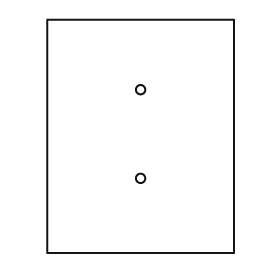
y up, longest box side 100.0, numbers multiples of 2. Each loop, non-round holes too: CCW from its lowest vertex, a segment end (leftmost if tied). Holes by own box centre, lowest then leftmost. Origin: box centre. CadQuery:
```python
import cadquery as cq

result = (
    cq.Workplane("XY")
    .moveTo(-40.0, -50.0)
    .lineTo(40.0, -50.0)
    .lineTo(40.0, 50.0)
    .lineTo(-40.0, 50.0)
    .close()
    .moveTo(0.0, -18.0)
    .circle(2.0)
    .moveTo(0.0, 20.0)
    .circle(2.0)
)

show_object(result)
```